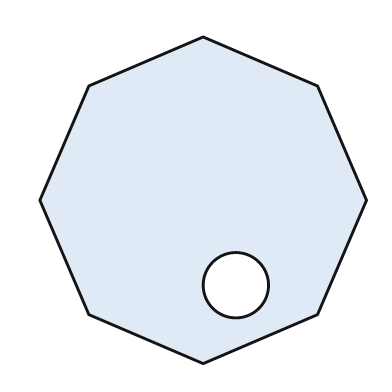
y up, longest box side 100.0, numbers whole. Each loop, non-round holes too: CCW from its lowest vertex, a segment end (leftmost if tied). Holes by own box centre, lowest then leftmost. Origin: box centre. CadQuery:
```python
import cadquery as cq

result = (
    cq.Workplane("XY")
    .moveTo(0.0, -50.0)
    .lineTo(35.0, -35.0)
    .lineTo(50.0, 0.0)
    .lineTo(35.0, 35.0)
    .lineTo(0.0, 50.0)
    .lineTo(-35.0, 35.0)
    .lineTo(-50.0, 0.0)
    .lineTo(-35.0, -35.0)
    .close()
    .moveTo(10.0, -26.0)
    .circle(10.0)
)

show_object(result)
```